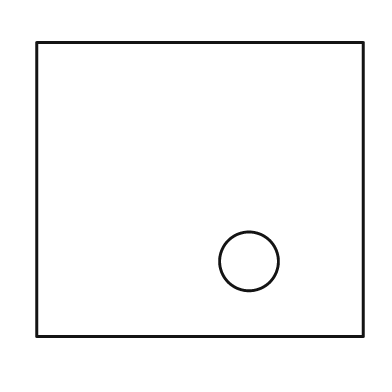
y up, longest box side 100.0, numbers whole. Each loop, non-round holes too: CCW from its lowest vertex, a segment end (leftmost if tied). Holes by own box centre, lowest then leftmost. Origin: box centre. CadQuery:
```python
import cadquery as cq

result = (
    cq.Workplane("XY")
    .moveTo(-50.0, -45.0)
    .lineTo(50.0, -45.0)
    .lineTo(50.0, 45.0)
    .lineTo(-50.0, 45.0)
    .close()
    .moveTo(15.0, -22.0)
    .circle(9.0)
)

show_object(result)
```